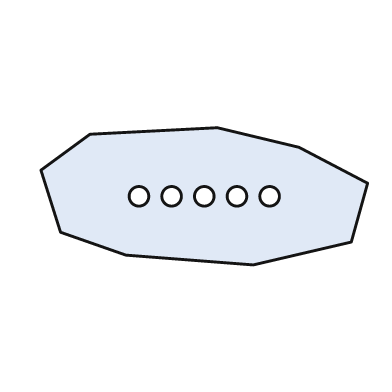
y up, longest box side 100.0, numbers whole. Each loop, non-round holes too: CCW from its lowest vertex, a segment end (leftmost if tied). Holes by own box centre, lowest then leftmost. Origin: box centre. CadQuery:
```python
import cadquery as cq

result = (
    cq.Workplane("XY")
    .moveTo(15.0, -21.0)
    .lineTo(45.0, -14.0)
    .lineTo(50.0, 4.0)
    .lineTo(29.0, 15.0)
    .lineTo(4.0, 21.0)
    .lineTo(-35.0, 19.0)
    .lineTo(-50.0, 8.0)
    .lineTo(-44.0, -11.0)
    .lineTo(-24.0, -18.0)
    .close()
    .moveTo(-20.0, 0.0)
    .circle(3.0)
    .moveTo(-10.0, 0.0)
    .circle(3.0)
    .moveTo(0.0, 0.0)
    .circle(3.0)
    .moveTo(10.0, 0.0)
    .circle(3.0)
    .moveTo(20.0, 0.0)
    .circle(3.0)
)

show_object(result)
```